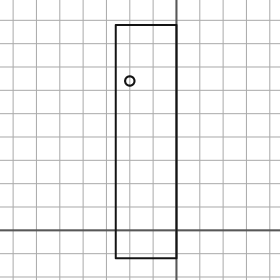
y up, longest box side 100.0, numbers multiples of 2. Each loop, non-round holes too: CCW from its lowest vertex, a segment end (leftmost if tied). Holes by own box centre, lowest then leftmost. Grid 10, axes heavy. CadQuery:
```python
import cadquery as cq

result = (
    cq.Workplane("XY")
    .moveTo(-26.0, -12.0)
    .lineTo(0.0, -12.0)
    .lineTo(0.0, 88.0)
    .lineTo(-26.0, 88.0)
    .close()
    .moveTo(-20.0, 64.0)
    .circle(2.0)
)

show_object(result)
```